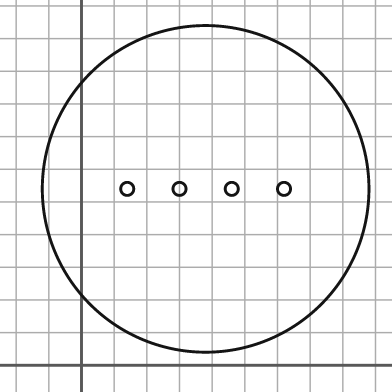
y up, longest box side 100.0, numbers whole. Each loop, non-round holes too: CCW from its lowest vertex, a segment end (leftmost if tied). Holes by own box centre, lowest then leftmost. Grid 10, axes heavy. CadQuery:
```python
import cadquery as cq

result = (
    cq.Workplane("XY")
    .moveTo(38.0, 54.0)
    .circle(50.0)
    .moveTo(14.0, 54.0)
    .circle(2.0)
    .moveTo(30.0, 54.0)
    .circle(2.0)
    .moveTo(46.0, 54.0)
    .circle(2.0)
    .moveTo(62.0, 54.0)
    .circle(2.0)
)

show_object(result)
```